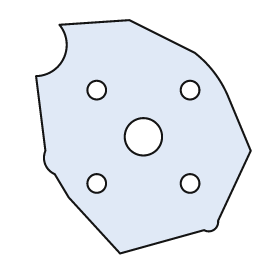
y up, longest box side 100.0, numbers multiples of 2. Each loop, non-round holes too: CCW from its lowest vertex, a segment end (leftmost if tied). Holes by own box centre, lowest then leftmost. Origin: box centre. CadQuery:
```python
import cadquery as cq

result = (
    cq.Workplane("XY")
    .moveTo(-10.0, -50.0)
    .lineTo(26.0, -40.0)
    .threePointArc((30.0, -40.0), (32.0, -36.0))
    .lineTo(46.0, -6.0)
    .lineTo(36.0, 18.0)
    .threePointArc((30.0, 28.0), (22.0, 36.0))
    .lineTo(-6.0, 50.0)
    .lineTo(-36.0, 48.0)
    .threePointArc((-34.0, 34.0), (-46.0, 26.0))
    .lineTo(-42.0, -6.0)
    .threePointArc((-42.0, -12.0), (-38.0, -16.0))
    .lineTo(-32.0, -26.0)
    .close()
    .moveTo(-20.0, -20.0)
    .circle(4.0)
    .moveTo(20.0, -20.0)
    .circle(4.0)
    .moveTo(0.0, 0.0)
    .circle(8.0)
    .moveTo(-20.0, 20.0)
    .circle(4.0)
    .moveTo(20.0, 20.0)
    .circle(4.0)
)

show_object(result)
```